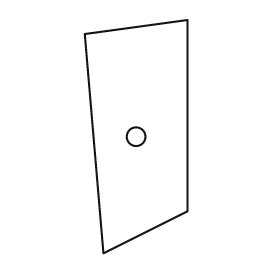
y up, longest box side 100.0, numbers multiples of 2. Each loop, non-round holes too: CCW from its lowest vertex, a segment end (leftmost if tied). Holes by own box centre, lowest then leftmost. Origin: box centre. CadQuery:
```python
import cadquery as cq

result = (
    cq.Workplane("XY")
    .moveTo(-14.0, -50.0)
    .lineTo(22.0, -32.0)
    .lineTo(22.0, 50.0)
    .lineTo(-22.0, 44.0)
    .close()
    .moveTo(0.0, 0.0)
    .circle(4.0)
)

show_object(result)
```